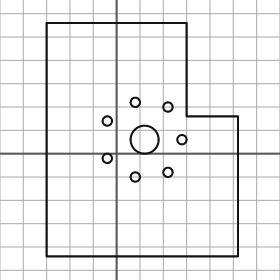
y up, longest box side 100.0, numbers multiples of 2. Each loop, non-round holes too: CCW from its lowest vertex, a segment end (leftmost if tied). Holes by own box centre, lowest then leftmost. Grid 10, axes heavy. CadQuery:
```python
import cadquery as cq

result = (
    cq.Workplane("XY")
    .moveTo(-30.0, -44.0)
    .lineTo(52.0, -44.0)
    .lineTo(52.0, 16.0)
    .lineTo(30.0, 16.0)
    .lineTo(30.0, 56.0)
    .lineTo(-30.0, 56.0)
    .close()
    .moveTo(8.0, -10.0)
    .circle(2.0)
    .moveTo(22.0, -8.0)
    .circle(2.0)
    .moveTo(-4.0, -2.0)
    .circle(2.0)
    .moveTo(12.0, 6.0)
    .circle(6.0)
    .moveTo(28.0, 6.0)
    .circle(2.0)
    .moveTo(-4.0, 14.0)
    .circle(2.0)
    .moveTo(22.0, 20.0)
    .circle(2.0)
    .moveTo(8.0, 22.0)
    .circle(2.0)
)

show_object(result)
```